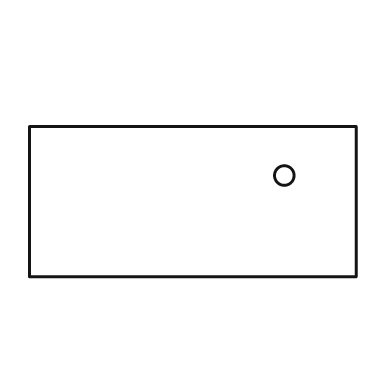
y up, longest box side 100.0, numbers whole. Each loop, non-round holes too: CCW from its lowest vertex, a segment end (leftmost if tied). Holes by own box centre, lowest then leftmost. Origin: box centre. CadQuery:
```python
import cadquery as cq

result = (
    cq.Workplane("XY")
    .moveTo(-50.0, -23.0)
    .lineTo(50.0, -23.0)
    .lineTo(50.0, 23.0)
    .lineTo(-50.0, 23.0)
    .close()
    .moveTo(28.0, 8.0)
    .circle(3.0)
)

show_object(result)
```